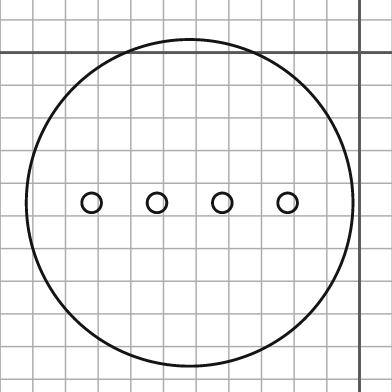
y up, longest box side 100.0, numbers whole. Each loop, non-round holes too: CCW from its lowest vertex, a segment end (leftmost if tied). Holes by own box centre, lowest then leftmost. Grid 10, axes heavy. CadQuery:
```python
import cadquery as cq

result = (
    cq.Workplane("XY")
    .moveTo(-52.0, -46.0)
    .circle(50.0)
    .moveTo(-82.0, -46.0)
    .circle(3.0)
    .moveTo(-62.0, -46.0)
    .circle(3.0)
    .moveTo(-42.0, -46.0)
    .circle(3.0)
    .moveTo(-22.0, -46.0)
    .circle(3.0)
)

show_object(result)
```